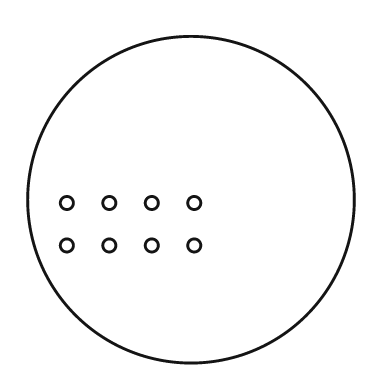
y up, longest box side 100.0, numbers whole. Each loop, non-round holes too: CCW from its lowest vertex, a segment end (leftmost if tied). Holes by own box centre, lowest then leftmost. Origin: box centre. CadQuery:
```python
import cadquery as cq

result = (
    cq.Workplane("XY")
    .moveTo(0.0, 0.0)
    .circle(50.0)
    .moveTo(-38.0, -14.0)
    .circle(2.0)
    .moveTo(-25.0, -14.0)
    .circle(2.0)
    .moveTo(-12.0, -14.0)
    .circle(2.0)
    .moveTo(1.0, -14.0)
    .circle(2.0)
    .moveTo(-38.0, -1.0)
    .circle(2.0)
    .moveTo(-25.0, -1.0)
    .circle(2.0)
    .moveTo(-12.0, -1.0)
    .circle(2.0)
    .moveTo(1.0, -1.0)
    .circle(2.0)
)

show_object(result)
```